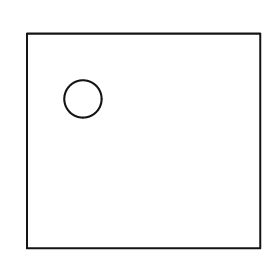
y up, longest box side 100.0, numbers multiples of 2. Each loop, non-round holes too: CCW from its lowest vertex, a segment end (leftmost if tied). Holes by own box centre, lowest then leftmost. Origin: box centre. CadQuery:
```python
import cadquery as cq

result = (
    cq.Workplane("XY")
    .moveTo(-50.0, -46.0)
    .lineTo(50.0, -46.0)
    .lineTo(50.0, 46.0)
    .lineTo(-50.0, 46.0)
    .close()
    .moveTo(-26.0, 18.0)
    .circle(8.0)
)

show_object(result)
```